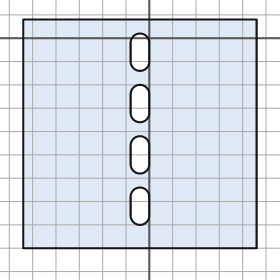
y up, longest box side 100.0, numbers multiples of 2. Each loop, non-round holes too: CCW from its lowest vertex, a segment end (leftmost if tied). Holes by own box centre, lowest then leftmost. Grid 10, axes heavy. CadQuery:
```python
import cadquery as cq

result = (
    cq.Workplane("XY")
    .moveTo(-54.0, -90.0)
    .lineTo(46.0, -90.0)
    .lineTo(46.0, 8.0)
    .lineTo(-54.0, 8.0)
    .close()
    .moveTo(-8.0, -76.0)
    .threePointArc((-4.0, -80.0), (0.0, -76.0))
    .lineTo(0.0, -68.0)
    .threePointArc((-4.0, -64.0), (-8.0, -68.0))
    .close()
    .moveTo(-8.0, -54.0)
    .threePointArc((-4.0, -58.0), (0.0, -54.0))
    .lineTo(0.0, -46.0)
    .threePointArc((-4.0, -42.0), (-8.0, -46.0))
    .close()
    .moveTo(-8.0, -32.0)
    .threePointArc((-4.0, -36.0), (0.0, -32.0))
    .lineTo(0.0, -24.0)
    .threePointArc((-4.0, -20.0), (-8.0, -24.0))
    .close()
    .moveTo(-8.0, -10.0)
    .threePointArc((-4.0, -14.0), (0.0, -10.0))
    .lineTo(0.0, -2.0)
    .threePointArc((-4.0, 2.0), (-8.0, -2.0))
    .close()
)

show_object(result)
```